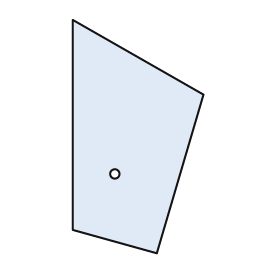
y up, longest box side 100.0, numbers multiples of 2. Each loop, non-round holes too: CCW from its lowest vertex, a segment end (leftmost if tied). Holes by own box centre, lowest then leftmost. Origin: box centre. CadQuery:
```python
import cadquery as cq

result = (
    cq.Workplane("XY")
    .moveTo(8.0, -50.0)
    .lineTo(28.0, 18.0)
    .lineTo(-28.0, 50.0)
    .lineTo(-28.0, -40.0)
    .close()
    .moveTo(-10.0, -16.0)
    .circle(2.0)
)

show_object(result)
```